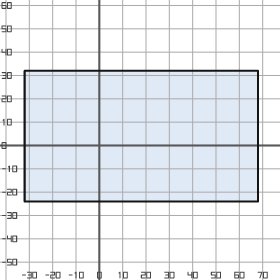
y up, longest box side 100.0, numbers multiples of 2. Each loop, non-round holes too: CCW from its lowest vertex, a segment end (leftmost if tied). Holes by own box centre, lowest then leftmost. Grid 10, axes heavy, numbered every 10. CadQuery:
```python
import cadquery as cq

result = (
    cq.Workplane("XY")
    .moveTo(-32.0, -24.0)
    .lineTo(68.0, -24.0)
    .lineTo(68.0, 32.0)
    .lineTo(-32.0, 32.0)
    .close()
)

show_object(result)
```